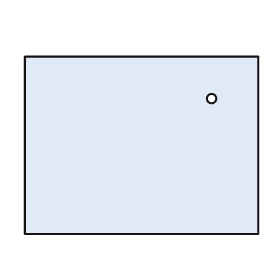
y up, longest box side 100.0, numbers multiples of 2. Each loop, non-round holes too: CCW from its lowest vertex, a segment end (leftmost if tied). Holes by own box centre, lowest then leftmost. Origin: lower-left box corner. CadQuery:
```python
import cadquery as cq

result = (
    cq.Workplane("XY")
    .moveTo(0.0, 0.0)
    .lineTo(100.0, 0.0)
    .lineTo(100.0, 76.0)
    .lineTo(0.0, 76.0)
    .close()
    .moveTo(80.0, 58.0)
    .circle(2.0)
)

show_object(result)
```